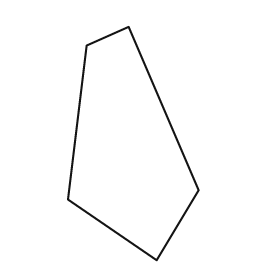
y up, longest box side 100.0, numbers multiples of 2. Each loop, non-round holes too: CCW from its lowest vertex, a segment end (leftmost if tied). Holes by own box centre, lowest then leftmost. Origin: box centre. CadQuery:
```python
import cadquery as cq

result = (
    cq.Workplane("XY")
    .moveTo(10.0, -50.0)
    .lineTo(28.0, -20.0)
    .lineTo(-2.0, 50.0)
    .lineTo(-20.0, 42.0)
    .lineTo(-28.0, -24.0)
    .close()
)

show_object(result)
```